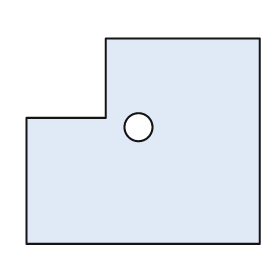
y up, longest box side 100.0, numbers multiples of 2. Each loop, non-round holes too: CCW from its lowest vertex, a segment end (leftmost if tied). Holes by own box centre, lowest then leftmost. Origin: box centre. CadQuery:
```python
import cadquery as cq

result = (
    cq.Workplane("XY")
    .moveTo(-50.0, -44.0)
    .lineTo(50.0, -44.0)
    .lineTo(50.0, 44.0)
    .lineTo(-16.0, 44.0)
    .lineTo(-16.0, 10.0)
    .lineTo(-50.0, 10.0)
    .close()
    .moveTo(-2.0, 6.0)
    .circle(6.0)
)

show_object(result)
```